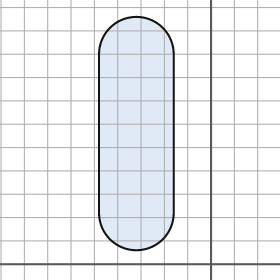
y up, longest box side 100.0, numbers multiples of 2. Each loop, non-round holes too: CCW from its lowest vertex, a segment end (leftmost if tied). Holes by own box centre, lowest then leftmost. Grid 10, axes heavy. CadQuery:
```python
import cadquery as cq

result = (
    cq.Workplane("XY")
    .moveTo(-48.0, 22.0)
    .threePointArc((-32.0, 6.0), (-16.0, 22.0))
    .lineTo(-16.0, 90.0)
    .threePointArc((-32.0, 106.0), (-48.0, 90.0))
    .close()
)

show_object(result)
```